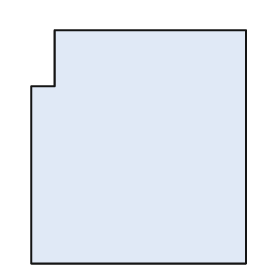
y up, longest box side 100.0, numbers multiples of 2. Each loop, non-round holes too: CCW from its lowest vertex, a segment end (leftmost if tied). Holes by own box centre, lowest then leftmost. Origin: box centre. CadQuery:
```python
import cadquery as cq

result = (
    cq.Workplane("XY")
    .moveTo(-46.0, -50.0)
    .lineTo(46.0, -50.0)
    .lineTo(46.0, 50.0)
    .lineTo(-36.0, 50.0)
    .lineTo(-36.0, 26.0)
    .lineTo(-46.0, 26.0)
    .close()
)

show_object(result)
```